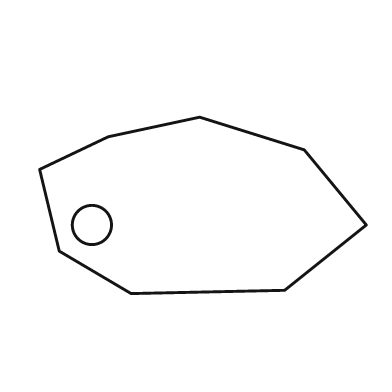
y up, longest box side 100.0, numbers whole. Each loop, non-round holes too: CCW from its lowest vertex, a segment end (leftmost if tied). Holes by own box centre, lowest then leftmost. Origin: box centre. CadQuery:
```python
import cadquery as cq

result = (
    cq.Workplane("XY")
    .moveTo(-22.0, -27.0)
    .lineTo(25.0, -26.0)
    .lineTo(50.0, -6.0)
    .lineTo(31.0, 17.0)
    .lineTo(-1.0, 27.0)
    .lineTo(-29.0, 21.0)
    .lineTo(-50.0, 11.0)
    .lineTo(-44.0, -14.0)
    .close()
    .moveTo(-34.0, -6.0)
    .circle(6.0)
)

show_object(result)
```